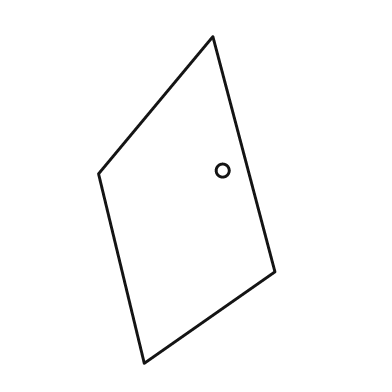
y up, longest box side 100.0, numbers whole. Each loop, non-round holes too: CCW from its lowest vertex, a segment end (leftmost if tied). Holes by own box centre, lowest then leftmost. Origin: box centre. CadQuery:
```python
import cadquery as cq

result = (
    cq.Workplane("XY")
    .moveTo(-13.0, -50.0)
    .lineTo(27.0, -22.0)
    .lineTo(8.0, 50.0)
    .lineTo(-27.0, 8.0)
    .close()
    .moveTo(11.0, 9.0)
    .circle(2.0)
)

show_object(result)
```